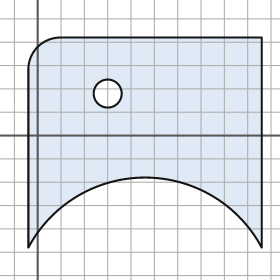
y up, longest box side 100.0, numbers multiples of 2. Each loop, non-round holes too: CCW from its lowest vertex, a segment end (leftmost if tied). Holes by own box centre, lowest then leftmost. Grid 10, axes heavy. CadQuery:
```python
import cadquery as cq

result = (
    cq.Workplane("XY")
    .moveTo(-4.0, -48.0)
    .threePointArc((46.0, -18.0), (96.0, -48.0))
    .lineTo(96.0, 42.0)
    .lineTo(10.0, 42.0)
    .threePointArc((0.0, 38.0), (-4.0, 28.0))
    .close()
    .moveTo(30.0, 18.0)
    .circle(6.0)
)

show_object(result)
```